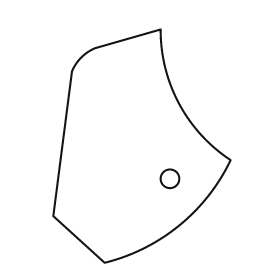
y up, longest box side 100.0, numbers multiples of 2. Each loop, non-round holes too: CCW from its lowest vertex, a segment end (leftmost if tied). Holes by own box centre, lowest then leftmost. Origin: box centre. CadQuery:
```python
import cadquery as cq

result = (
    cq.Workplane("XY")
    .moveTo(-16.0, -50.0)
    .threePointArc((16.0, -34.0), (38.0, -6.0))
    .threePointArc((16.0, 18.0), (8.0, 50.0))
    .lineTo(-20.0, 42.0)
    .threePointArc((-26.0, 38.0), (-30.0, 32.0))
    .lineTo(-38.0, -30.0)
    .close()
    .moveTo(12.0, -14.0)
    .circle(4.0)
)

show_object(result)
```